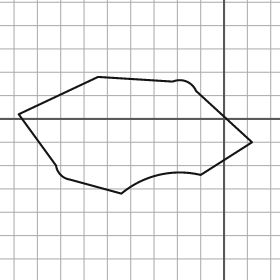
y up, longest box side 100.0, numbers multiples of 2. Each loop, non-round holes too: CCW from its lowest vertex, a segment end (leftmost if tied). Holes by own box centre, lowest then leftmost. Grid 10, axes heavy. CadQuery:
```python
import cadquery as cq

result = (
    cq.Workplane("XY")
    .moveTo(-44.0, -32.0)
    .threePointArc((-28.0, -24.0), (-10.0, -24.0))
    .lineTo(12.0, -10.0)
    .lineTo(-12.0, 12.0)
    .threePointArc((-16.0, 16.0), (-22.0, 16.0))
    .lineTo(-54.0, 18.0)
    .lineTo(-88.0, 2.0)
    .lineTo(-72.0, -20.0)
    .threePointArc((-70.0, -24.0), (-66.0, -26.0))
    .close()
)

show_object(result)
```